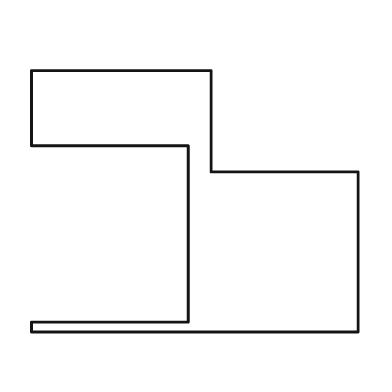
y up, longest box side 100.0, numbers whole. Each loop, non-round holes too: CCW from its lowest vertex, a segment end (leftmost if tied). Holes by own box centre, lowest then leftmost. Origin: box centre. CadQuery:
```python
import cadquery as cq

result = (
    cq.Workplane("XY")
    .moveTo(-50.0, -40.0)
    .lineTo(50.0, -40.0)
    .lineTo(50.0, 9.0)
    .lineTo(5.0, 9.0)
    .lineTo(5.0, 40.0)
    .lineTo(-50.0, 40.0)
    .lineTo(-50.0, 17.0)
    .lineTo(-2.0, 17.0)
    .lineTo(-2.0, -37.0)
    .lineTo(-50.0, -37.0)
    .close()
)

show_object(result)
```